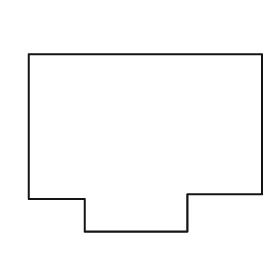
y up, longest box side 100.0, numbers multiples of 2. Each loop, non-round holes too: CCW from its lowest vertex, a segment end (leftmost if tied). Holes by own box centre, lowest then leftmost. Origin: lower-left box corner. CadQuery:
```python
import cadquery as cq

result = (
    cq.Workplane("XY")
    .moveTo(24.0, 0.0)
    .lineTo(68.0, 0.0)
    .lineTo(68.0, 16.0)
    .lineTo(100.0, 16.0)
    .lineTo(100.0, 76.0)
    .lineTo(0.0, 76.0)
    .lineTo(0.0, 14.0)
    .lineTo(24.0, 14.0)
    .close()
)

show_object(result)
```